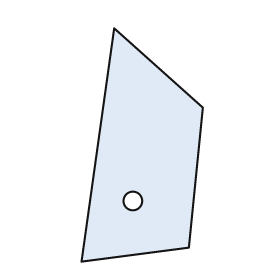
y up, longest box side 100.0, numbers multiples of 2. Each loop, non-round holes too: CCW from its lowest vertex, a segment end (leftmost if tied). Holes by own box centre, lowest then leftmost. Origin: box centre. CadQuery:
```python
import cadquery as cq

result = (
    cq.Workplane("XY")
    .moveTo(-26.0, -50.0)
    .lineTo(20.0, -44.0)
    .lineTo(26.0, 16.0)
    .lineTo(-12.0, 50.0)
    .close()
    .moveTo(-4.0, -24.0)
    .circle(4.0)
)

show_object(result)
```